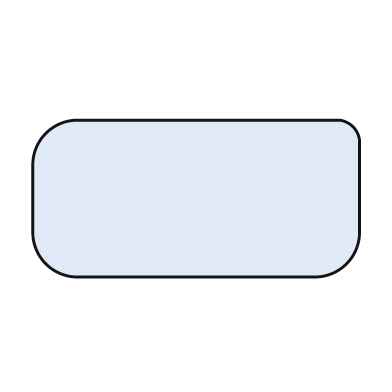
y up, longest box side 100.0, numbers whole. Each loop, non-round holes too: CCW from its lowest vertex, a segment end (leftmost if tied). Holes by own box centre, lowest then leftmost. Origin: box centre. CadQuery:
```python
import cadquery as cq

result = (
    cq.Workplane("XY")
    .moveTo(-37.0, -24.0)
    .lineTo(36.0, -24.0)
    .threePointArc((46.0, -20.0), (50.0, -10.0))
    .lineTo(50.0, 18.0)
    .threePointArc((48.0, 22.0), (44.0, 24.0))
    .lineTo(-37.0, 24.0)
    .threePointArc((-46.0, 20.0), (-50.0, 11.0))
    .lineTo(-50.0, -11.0)
    .threePointArc((-46.0, -20.0), (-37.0, -24.0))
    .close()
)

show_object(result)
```